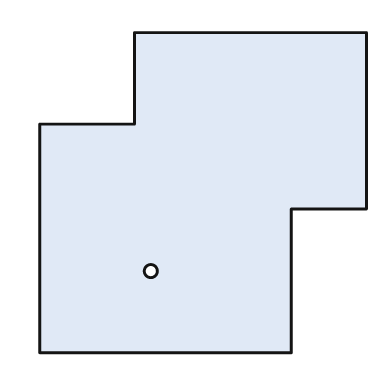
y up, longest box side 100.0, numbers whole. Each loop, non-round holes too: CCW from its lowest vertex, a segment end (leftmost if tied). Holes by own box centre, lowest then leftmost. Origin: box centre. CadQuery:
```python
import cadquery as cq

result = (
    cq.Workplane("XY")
    .moveTo(-50.0, -49.0)
    .lineTo(27.0, -49.0)
    .lineTo(27.0, -5.0)
    .lineTo(50.0, -5.0)
    .lineTo(50.0, 49.0)
    .lineTo(-21.0, 49.0)
    .lineTo(-21.0, 21.0)
    .lineTo(-50.0, 21.0)
    .close()
    .moveTo(-16.0, -24.0)
    .circle(2.0)
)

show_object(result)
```